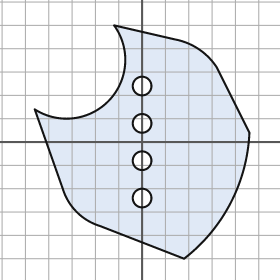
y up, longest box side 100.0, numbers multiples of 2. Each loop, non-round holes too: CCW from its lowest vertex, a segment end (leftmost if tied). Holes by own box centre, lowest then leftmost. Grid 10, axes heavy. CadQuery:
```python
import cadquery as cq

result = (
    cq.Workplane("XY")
    .moveTo(18.0, -50.0)
    .threePointArc((38.0, -26.0), (46.0, 4.0))
    .lineTo(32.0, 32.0)
    .threePointArc((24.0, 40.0), (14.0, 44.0))
    .lineTo(-12.0, 50.0)
    .threePointArc((-14.0, 18.0), (-46.0, 14.0))
    .lineTo(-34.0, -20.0)
    .threePointArc((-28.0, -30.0), (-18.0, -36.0))
    .close()
    .moveTo(0.0, -24.0)
    .circle(4.0)
    .moveTo(0.0, -8.0)
    .circle(4.0)
    .moveTo(0.0, 8.0)
    .circle(4.0)
    .moveTo(0.0, 24.0)
    .circle(4.0)
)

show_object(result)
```